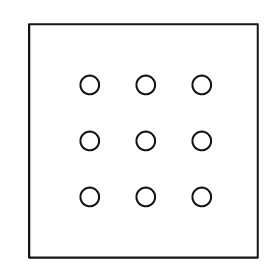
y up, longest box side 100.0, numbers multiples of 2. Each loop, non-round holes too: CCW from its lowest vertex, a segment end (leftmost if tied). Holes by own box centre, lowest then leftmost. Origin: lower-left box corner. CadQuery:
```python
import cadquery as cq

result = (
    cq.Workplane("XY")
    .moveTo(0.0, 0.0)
    .lineTo(98.0, 0.0)
    .lineTo(98.0, 100.0)
    .lineTo(0.0, 100.0)
    .close()
    .moveTo(26.0, 26.0)
    .circle(4.0)
    .moveTo(50.0, 26.0)
    .circle(4.0)
    .moveTo(74.0, 26.0)
    .circle(4.0)
    .moveTo(26.0, 50.0)
    .circle(4.0)
    .moveTo(50.0, 50.0)
    .circle(4.0)
    .moveTo(74.0, 50.0)
    .circle(4.0)
    .moveTo(26.0, 74.0)
    .circle(4.0)
    .moveTo(50.0, 74.0)
    .circle(4.0)
    .moveTo(74.0, 74.0)
    .circle(4.0)
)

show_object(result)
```